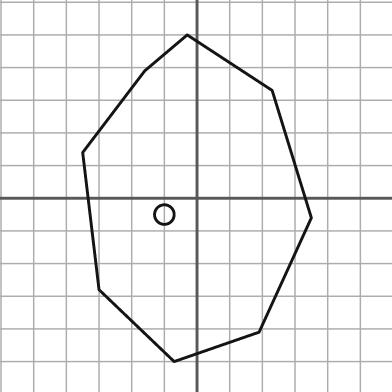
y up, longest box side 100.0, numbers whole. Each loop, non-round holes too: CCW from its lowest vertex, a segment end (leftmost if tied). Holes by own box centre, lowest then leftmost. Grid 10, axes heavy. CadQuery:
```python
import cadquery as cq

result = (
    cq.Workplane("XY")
    .moveTo(-7.0, -50.0)
    .lineTo(19.0, -41.0)
    .lineTo(35.0, -6.0)
    .lineTo(23.0, 33.0)
    .lineTo(-3.0, 50.0)
    .lineTo(-16.0, 39.0)
    .lineTo(-35.0, 14.0)
    .lineTo(-30.0, -28.0)
    .close()
    .moveTo(-10.0, -5.0)
    .circle(3.0)
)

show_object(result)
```